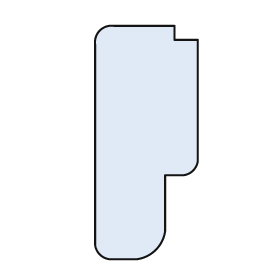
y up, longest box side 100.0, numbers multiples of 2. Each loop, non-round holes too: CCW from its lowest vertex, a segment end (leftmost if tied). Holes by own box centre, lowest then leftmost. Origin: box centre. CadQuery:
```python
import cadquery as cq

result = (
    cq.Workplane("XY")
    .moveTo(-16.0, -50.0)
    .lineTo(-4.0, -50.0)
    .threePointArc((4.0, -46.0), (8.0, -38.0))
    .lineTo(8.0, -14.0)
    .lineTo(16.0, -14.0)
    .threePointArc((20.0, -12.0), (22.0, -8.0))
    .lineTo(22.0, 44.0)
    .lineTo(12.0, 44.0)
    .lineTo(12.0, 50.0)
    .lineTo(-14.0, 50.0)
    .threePointArc((-20.0, 48.0), (-22.0, 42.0))
    .lineTo(-22.0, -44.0)
    .threePointArc((-20.0, -48.0), (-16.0, -50.0))
    .close()
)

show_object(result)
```